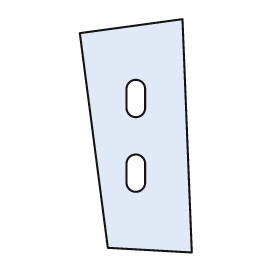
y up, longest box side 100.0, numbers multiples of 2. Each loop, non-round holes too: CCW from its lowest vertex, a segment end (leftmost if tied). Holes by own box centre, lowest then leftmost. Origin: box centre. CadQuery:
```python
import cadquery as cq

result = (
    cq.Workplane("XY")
    .moveTo(24.0, -50.0)
    .lineTo(20.0, 50.0)
    .lineTo(-24.0, 44.0)
    .lineTo(-12.0, -48.0)
    .close()
    .moveTo(-4.0, -20.0)
    .threePointArc((0.0, -24.0), (4.0, -20.0))
    .lineTo(4.0, -12.0)
    .threePointArc((0.0, -8.0), (-4.0, -12.0))
    .close()
    .moveTo(-4.0, 12.0)
    .threePointArc((0.0, 8.0), (4.0, 12.0))
    .lineTo(4.0, 20.0)
    .threePointArc((0.0, 24.0), (-4.0, 20.0))
    .close()
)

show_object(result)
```